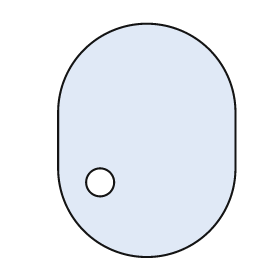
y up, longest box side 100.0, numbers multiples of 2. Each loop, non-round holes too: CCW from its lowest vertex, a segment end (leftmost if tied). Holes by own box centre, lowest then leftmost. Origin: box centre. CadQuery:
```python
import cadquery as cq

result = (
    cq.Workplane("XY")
    .moveTo(-38.0, -12.0)
    .threePointArc((0.0, -50.0), (38.0, -12.0))
    .lineTo(38.0, 12.0)
    .threePointArc((0.0, 50.0), (-38.0, 12.0))
    .close()
    .moveTo(-20.0, -18.0)
    .circle(6.0)
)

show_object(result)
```